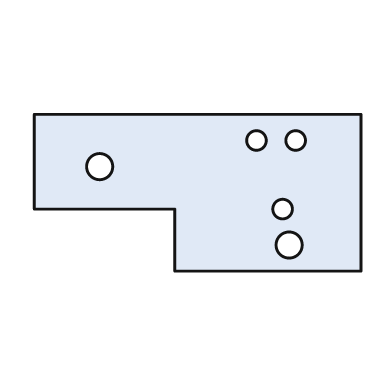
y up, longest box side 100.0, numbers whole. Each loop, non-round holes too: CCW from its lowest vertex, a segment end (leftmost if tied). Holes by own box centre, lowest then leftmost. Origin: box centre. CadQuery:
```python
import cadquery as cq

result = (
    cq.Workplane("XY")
    .moveTo(-7.0, -24.0)
    .lineTo(50.0, -24.0)
    .lineTo(50.0, 24.0)
    .lineTo(-50.0, 24.0)
    .lineTo(-50.0, -5.0)
    .lineTo(-7.0, -5.0)
    .close()
    .moveTo(28.0, -16.0)
    .circle(4.0)
    .moveTo(26.0, -5.0)
    .circle(3.0)
    .moveTo(-30.0, 8.0)
    .circle(4.0)
    .moveTo(18.0, 16.0)
    .circle(3.0)
    .moveTo(30.0, 16.0)
    .circle(3.0)
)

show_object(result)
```